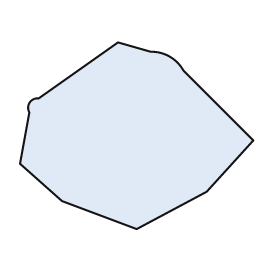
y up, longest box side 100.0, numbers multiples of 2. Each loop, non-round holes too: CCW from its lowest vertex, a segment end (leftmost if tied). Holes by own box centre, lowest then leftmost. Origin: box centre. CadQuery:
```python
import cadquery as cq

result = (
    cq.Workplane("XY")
    .moveTo(0.0, -40.0)
    .lineTo(30.0, -24.0)
    .lineTo(50.0, -2.0)
    .lineTo(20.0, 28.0)
    .threePointArc((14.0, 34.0), (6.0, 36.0))
    .lineTo(-8.0, 40.0)
    .lineTo(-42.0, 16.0)
    .threePointArc((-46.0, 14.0), (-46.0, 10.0))
    .lineTo(-50.0, -12.0)
    .lineTo(-32.0, -28.0)
    .close()
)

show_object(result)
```